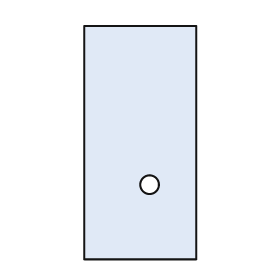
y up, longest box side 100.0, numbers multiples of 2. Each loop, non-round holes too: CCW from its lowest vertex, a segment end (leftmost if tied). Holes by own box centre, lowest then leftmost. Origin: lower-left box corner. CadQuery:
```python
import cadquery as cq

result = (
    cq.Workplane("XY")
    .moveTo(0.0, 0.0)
    .lineTo(48.0, 0.0)
    .lineTo(48.0, 100.0)
    .lineTo(0.0, 100.0)
    .close()
    .moveTo(28.0, 32.0)
    .circle(4.0)
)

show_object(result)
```